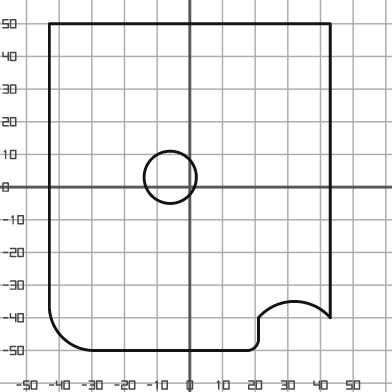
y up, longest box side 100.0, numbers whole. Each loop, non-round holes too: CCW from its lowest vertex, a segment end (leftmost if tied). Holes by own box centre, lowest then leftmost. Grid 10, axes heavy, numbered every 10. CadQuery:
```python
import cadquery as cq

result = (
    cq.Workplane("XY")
    .moveTo(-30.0, -50.0)
    .lineTo(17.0, -50.0)
    .threePointArc((20.0, -49.0), (21.0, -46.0))
    .lineTo(21.0, -40.0)
    .threePointArc((32.0, -35.0), (43.0, -40.0))
    .lineTo(43.0, 50.0)
    .lineTo(-43.0, 50.0)
    .lineTo(-43.0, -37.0)
    .threePointArc((-39.0, -46.0), (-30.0, -50.0))
    .close()
    .moveTo(-6.0, 3.0)
    .circle(8.0)
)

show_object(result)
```